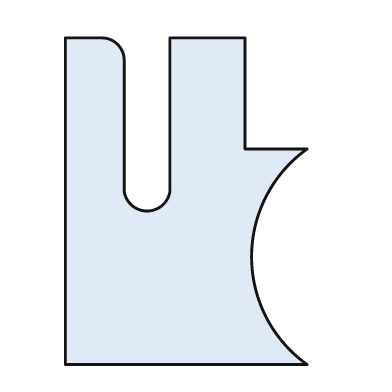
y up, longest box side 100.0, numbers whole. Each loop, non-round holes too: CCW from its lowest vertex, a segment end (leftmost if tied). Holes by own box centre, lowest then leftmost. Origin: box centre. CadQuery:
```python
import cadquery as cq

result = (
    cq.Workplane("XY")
    .moveTo(-37.0, -50.0)
    .lineTo(37.0, -50.0)
    .threePointArc((20.0, -17.0), (37.0, 16.0))
    .lineTo(18.0, 16.0)
    .lineTo(18.0, 50.0)
    .lineTo(-5.0, 50.0)
    .lineTo(-5.0, 3.0)
    .threePointArc((-12.0, -3.0), (-19.0, 3.0))
    .lineTo(-19.0, 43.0)
    .threePointArc((-21.0, 48.0), (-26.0, 50.0))
    .lineTo(-37.0, 50.0)
    .close()
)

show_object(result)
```